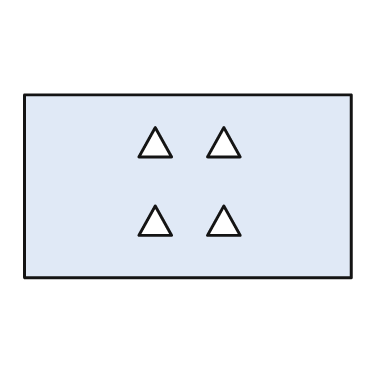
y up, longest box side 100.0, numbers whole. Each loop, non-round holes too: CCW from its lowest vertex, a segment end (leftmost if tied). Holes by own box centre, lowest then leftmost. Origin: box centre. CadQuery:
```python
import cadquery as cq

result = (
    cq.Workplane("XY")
    .moveTo(-50.0, -28.0)
    .lineTo(50.0, -28.0)
    .lineTo(50.0, 28.0)
    .lineTo(-50.0, 28.0)
    .close()
    .moveTo(-15.0, -15.0)
    .lineTo(-5.0, -15.0)
    .lineTo(-10.0, -6.0)
    .close()
    .moveTo(6.0, -15.0)
    .lineTo(16.0, -15.0)
    .lineTo(11.0, -6.0)
    .close()
    .moveTo(-15.0, 9.0)
    .lineTo(-5.0, 9.0)
    .lineTo(-10.0, 18.0)
    .close()
    .moveTo(6.0, 9.0)
    .lineTo(16.0, 9.0)
    .lineTo(11.0, 18.0)
    .close()
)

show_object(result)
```